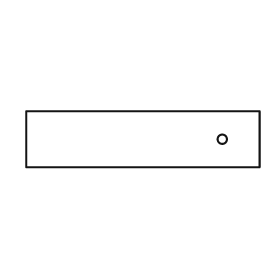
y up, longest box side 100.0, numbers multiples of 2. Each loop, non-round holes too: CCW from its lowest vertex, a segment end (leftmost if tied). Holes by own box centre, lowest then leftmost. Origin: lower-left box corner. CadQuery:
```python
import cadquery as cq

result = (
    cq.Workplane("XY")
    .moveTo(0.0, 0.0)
    .lineTo(100.0, 0.0)
    .lineTo(100.0, 24.0)
    .lineTo(0.0, 24.0)
    .close()
    .moveTo(84.0, 12.0)
    .circle(2.0)
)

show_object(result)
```